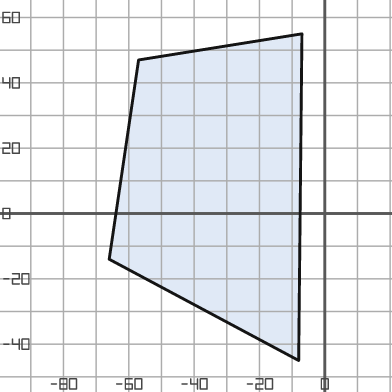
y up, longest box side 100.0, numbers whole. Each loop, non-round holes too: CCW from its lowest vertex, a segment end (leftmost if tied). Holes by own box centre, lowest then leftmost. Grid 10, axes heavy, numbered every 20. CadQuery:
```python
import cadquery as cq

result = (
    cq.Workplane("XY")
    .moveTo(-8.0, -45.0)
    .lineTo(-7.0, 55.0)
    .lineTo(-57.0, 47.0)
    .lineTo(-66.0, -14.0)
    .close()
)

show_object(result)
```